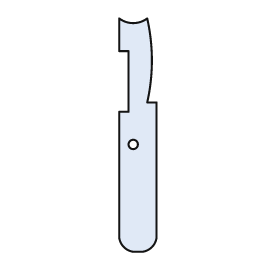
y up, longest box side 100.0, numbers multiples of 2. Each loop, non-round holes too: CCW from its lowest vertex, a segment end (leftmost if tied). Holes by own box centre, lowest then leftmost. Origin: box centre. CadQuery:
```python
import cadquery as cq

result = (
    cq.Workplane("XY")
    .moveTo(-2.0, -50.0)
    .lineTo(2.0, -50.0)
    .threePointArc((6.0, -48.0), (8.0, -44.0))
    .lineTo(8.0, 14.0)
    .lineTo(4.0, 14.0)
    .threePointArc((6.0, 32.0), (4.0, 50.0))
    .threePointArc((-2.0, 48.0), (-8.0, 50.0))
    .lineTo(-8.0, 36.0)
    .lineTo(-4.0, 36.0)
    .lineTo(-4.0, 10.0)
    .lineTo(-8.0, 10.0)
    .lineTo(-8.0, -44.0)
    .threePointArc((-6.0, -48.0), (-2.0, -50.0))
    .close()
    .moveTo(-2.0, -4.0)
    .circle(2.0)
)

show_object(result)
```